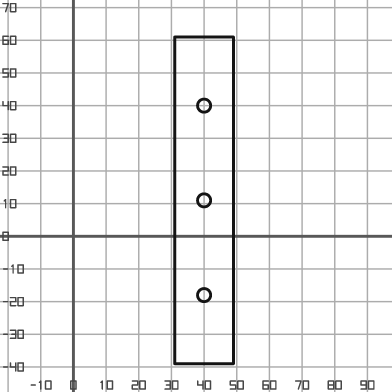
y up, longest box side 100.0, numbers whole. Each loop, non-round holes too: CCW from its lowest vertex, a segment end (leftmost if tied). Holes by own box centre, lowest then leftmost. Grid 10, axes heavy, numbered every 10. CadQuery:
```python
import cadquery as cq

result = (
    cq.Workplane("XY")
    .moveTo(31.0, -39.0)
    .lineTo(49.0, -39.0)
    .lineTo(49.0, 61.0)
    .lineTo(31.0, 61.0)
    .close()
    .moveTo(40.0, -18.0)
    .circle(2.0)
    .moveTo(40.0, 11.0)
    .circle(2.0)
    .moveTo(40.0, 40.0)
    .circle(2.0)
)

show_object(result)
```